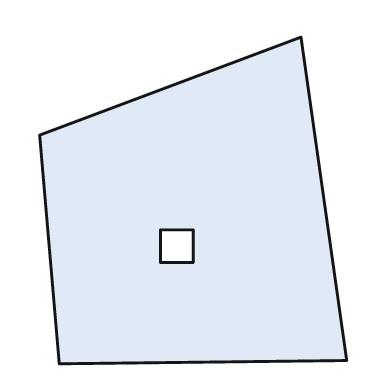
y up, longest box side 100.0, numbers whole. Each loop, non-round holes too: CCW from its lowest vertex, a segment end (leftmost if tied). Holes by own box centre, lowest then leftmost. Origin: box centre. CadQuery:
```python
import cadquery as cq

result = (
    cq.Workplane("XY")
    .moveTo(-41.0, -50.0)
    .lineTo(47.0, -49.0)
    .lineTo(33.0, 50.0)
    .lineTo(-47.0, 20.0)
    .close()
    .moveTo(-10.0, -19.0)
    .lineTo(0.0, -19.0)
    .lineTo(0.0, -9.0)
    .lineTo(-10.0, -9.0)
    .close()
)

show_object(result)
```